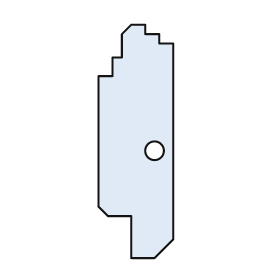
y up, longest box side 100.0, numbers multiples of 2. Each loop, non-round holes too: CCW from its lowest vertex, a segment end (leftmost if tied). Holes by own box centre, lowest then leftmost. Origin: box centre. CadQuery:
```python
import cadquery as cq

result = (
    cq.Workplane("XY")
    .moveTo(-2.0, -50.0)
    .lineTo(8.0, -50.0)
    .lineTo(16.0, -42.0)
    .lineTo(16.0, 42.0)
    .lineTo(10.0, 42.0)
    .lineTo(10.0, 46.0)
    .lineTo(4.0, 46.0)
    .lineTo(4.0, 50.0)
    .lineTo(-2.0, 50.0)
    .lineTo(-6.0, 46.0)
    .lineTo(-6.0, 36.0)
    .lineTo(-10.0, 36.0)
    .lineTo(-10.0, 28.0)
    .lineTo(-16.0, 28.0)
    .lineTo(-16.0, -28.0)
    .lineTo(-12.0, -32.0)
    .lineTo(-2.0, -32.0)
    .close()
    .moveTo(8.0, -4.0)
    .circle(4.0)
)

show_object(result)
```